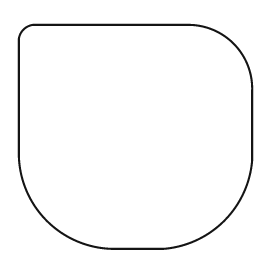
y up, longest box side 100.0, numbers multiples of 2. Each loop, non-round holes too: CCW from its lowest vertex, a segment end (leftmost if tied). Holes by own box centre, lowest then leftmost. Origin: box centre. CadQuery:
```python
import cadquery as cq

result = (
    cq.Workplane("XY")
    .moveTo(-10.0, -48.0)
    .lineTo(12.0, -48.0)
    .threePointArc((38.0, -36.0), (50.0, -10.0))
    .lineTo(50.0, 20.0)
    .threePointArc((42.0, 40.0), (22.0, 48.0))
    .lineTo(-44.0, 48.0)
    .threePointArc((-48.0, 46.0), (-50.0, 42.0))
    .lineTo(-50.0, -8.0)
    .threePointArc((-38.0, -36.0), (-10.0, -48.0))
    .close()
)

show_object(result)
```